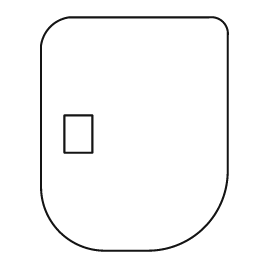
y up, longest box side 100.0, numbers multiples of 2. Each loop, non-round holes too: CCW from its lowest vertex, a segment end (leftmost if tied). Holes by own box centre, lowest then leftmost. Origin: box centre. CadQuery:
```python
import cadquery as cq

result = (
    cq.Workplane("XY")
    .moveTo(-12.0, -50.0)
    .lineTo(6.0, -50.0)
    .threePointArc((30.0, -40.0), (40.0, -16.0))
    .lineTo(40.0, 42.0)
    .threePointArc((38.0, 48.0), (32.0, 50.0))
    .lineTo(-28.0, 50.0)
    .threePointArc((-36.0, 46.0), (-40.0, 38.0))
    .lineTo(-40.0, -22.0)
    .threePointArc((-32.0, -42.0), (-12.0, -50.0))
    .close()
    .moveTo(-30.0, -8.0)
    .lineTo(-18.0, -8.0)
    .lineTo(-18.0, 8.0)
    .lineTo(-30.0, 8.0)
    .close()
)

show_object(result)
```